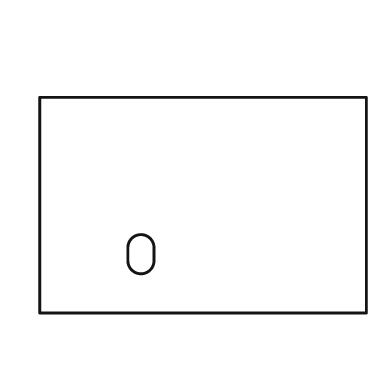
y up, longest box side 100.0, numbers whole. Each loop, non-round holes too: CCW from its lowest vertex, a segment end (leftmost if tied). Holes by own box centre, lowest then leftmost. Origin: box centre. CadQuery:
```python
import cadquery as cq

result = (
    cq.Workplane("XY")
    .moveTo(-50.0, -33.0)
    .lineTo(50.0, -33.0)
    .lineTo(50.0, 33.0)
    .lineTo(-50.0, 33.0)
    .close()
    .moveTo(-23.0, -17.0)
    .threePointArc((-19.0, -21.0), (-15.0, -17.0))
    .lineTo(-15.0, -13.0)
    .threePointArc((-19.0, -9.0), (-23.0, -13.0))
    .close()
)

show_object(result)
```